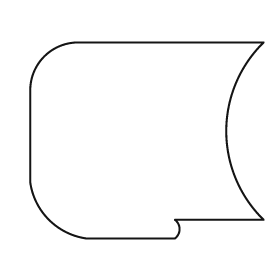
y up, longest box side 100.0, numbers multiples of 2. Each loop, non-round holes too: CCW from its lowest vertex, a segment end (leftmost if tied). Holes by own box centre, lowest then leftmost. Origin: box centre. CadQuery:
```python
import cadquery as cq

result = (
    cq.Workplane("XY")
    .moveTo(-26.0, -42.0)
    .lineTo(12.0, -42.0)
    .threePointArc((14.0, -38.0), (12.0, -34.0))
    .lineTo(50.0, -34.0)
    .threePointArc((34.0, 4.0), (50.0, 42.0))
    .lineTo(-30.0, 42.0)
    .threePointArc((-44.0, 36.0), (-50.0, 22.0))
    .lineTo(-50.0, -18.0)
    .threePointArc((-42.0, -34.0), (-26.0, -42.0))
    .close()
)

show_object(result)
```